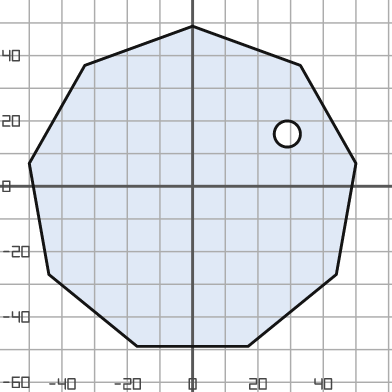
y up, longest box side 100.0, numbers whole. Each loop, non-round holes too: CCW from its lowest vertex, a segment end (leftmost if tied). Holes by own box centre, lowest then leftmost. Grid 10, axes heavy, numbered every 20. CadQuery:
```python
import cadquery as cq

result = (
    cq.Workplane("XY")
    .moveTo(-17.0, -49.0)
    .lineTo(17.0, -49.0)
    .lineTo(44.0, -27.0)
    .lineTo(50.0, 7.0)
    .lineTo(33.0, 37.0)
    .lineTo(0.0, 49.0)
    .lineTo(-33.0, 37.0)
    .lineTo(-50.0, 7.0)
    .lineTo(-44.0, -27.0)
    .close()
    .moveTo(29.0, 16.0)
    .circle(4.0)
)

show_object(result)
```